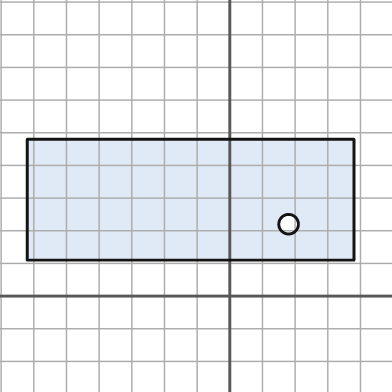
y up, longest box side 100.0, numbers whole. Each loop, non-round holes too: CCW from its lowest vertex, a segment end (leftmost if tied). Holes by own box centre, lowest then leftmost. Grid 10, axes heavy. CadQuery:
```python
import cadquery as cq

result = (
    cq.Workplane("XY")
    .moveTo(-62.0, 11.0)
    .lineTo(38.0, 11.0)
    .lineTo(38.0, 48.0)
    .lineTo(-62.0, 48.0)
    .close()
    .moveTo(18.0, 22.0)
    .circle(3.0)
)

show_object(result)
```